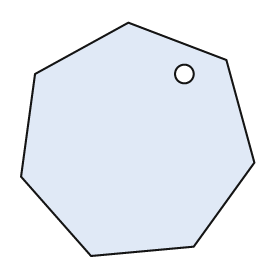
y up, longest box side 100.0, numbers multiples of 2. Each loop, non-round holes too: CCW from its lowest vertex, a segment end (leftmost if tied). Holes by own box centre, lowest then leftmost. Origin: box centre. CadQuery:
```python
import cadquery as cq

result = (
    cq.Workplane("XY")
    .moveTo(-20.0, -50.0)
    .lineTo(24.0, -46.0)
    .lineTo(50.0, -10.0)
    .lineTo(38.0, 34.0)
    .lineTo(-4.0, 50.0)
    .lineTo(-44.0, 28.0)
    .lineTo(-50.0, -16.0)
    .close()
    .moveTo(20.0, 28.0)
    .circle(4.0)
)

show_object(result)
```